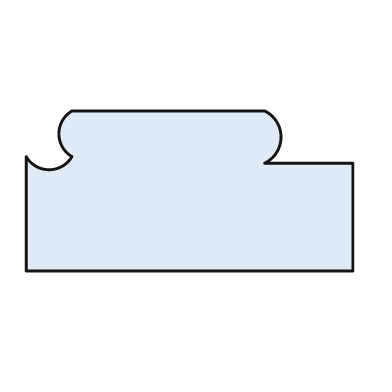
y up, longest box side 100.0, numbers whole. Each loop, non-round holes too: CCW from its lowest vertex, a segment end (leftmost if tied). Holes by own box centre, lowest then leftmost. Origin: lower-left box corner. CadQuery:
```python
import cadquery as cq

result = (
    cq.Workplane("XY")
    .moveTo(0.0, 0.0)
    .lineTo(100.0, 0.0)
    .lineTo(100.0, 33.0)
    .lineTo(73.0, 33.0)
    .threePointArc((78.0, 41.0), (73.0, 49.0))
    .lineTo(14.0, 49.0)
    .threePointArc((10.0, 42.0), (14.0, 35.0))
    .threePointArc((7.0, 31.0), (0.0, 35.0))
    .close()
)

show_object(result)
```